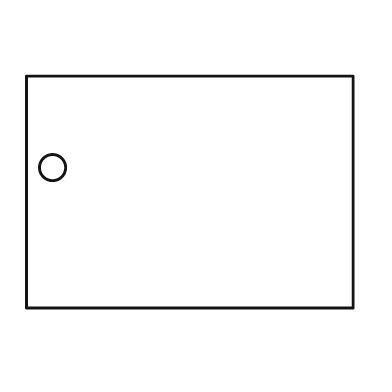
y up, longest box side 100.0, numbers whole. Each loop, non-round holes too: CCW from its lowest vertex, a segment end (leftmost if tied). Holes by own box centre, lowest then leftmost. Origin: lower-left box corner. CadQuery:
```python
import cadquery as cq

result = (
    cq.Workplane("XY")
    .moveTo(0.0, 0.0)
    .lineTo(100.0, 0.0)
    .lineTo(100.0, 71.0)
    .lineTo(0.0, 71.0)
    .close()
    .moveTo(8.0, 43.0)
    .circle(4.0)
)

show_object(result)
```